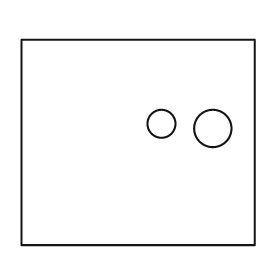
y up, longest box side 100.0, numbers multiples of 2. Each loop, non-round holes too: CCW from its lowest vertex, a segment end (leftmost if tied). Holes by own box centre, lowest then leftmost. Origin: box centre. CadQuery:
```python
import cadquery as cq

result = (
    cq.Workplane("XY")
    .moveTo(-50.0, -44.0)
    .lineTo(50.0, -44.0)
    .lineTo(50.0, 44.0)
    .lineTo(-50.0, 44.0)
    .close()
    .moveTo(32.0, 6.0)
    .circle(8.0)
    .moveTo(10.0, 8.0)
    .circle(6.0)
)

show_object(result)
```